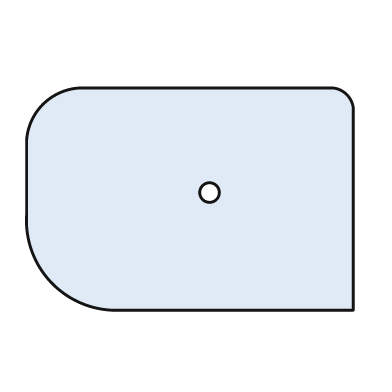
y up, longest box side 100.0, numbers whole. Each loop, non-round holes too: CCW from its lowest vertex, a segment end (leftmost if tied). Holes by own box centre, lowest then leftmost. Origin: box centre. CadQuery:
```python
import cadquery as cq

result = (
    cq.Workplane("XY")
    .moveTo(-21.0, -34.0)
    .lineTo(50.0, -34.0)
    .lineTo(50.0, 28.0)
    .threePointArc((48.0, 32.0), (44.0, 34.0))
    .lineTo(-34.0, 34.0)
    .threePointArc((-45.0, 29.0), (-50.0, 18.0))
    .lineTo(-50.0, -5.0)
    .threePointArc((-42.0, -26.0), (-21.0, -34.0))
    .close()
    .moveTo(6.0, 2.0)
    .circle(3.0)
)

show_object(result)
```